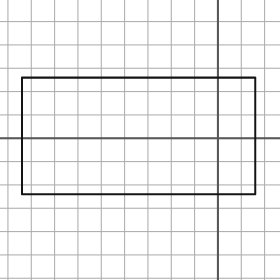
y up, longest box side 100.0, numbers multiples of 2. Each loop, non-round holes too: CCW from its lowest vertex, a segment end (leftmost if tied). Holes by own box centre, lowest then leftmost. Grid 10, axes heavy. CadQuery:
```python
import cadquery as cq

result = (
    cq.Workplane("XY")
    .moveTo(-84.0, -24.0)
    .lineTo(16.0, -24.0)
    .lineTo(16.0, 26.0)
    .lineTo(-84.0, 26.0)
    .close()
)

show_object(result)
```